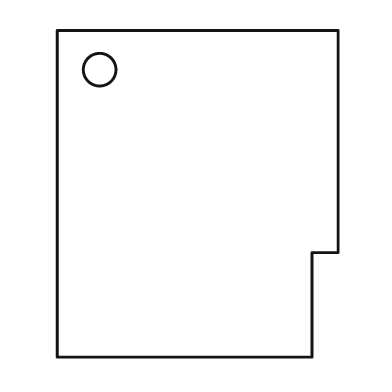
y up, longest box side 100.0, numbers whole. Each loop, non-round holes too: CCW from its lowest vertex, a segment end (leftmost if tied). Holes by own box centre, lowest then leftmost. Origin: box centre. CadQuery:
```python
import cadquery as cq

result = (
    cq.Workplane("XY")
    .moveTo(-43.0, -50.0)
    .lineTo(35.0, -50.0)
    .lineTo(35.0, -18.0)
    .lineTo(43.0, -18.0)
    .lineTo(43.0, 50.0)
    .lineTo(-43.0, 50.0)
    .close()
    .moveTo(-30.0, 38.0)
    .circle(5.0)
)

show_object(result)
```